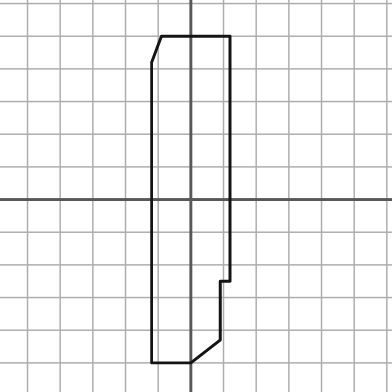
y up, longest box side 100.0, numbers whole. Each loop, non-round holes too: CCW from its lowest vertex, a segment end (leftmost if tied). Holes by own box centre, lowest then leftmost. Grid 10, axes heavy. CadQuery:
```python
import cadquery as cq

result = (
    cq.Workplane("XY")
    .moveTo(-12.0, -50.0)
    .lineTo(0.0, -50.0)
    .lineTo(9.0, -43.0)
    .lineTo(9.0, -25.0)
    .lineTo(12.0, -25.0)
    .lineTo(12.0, 50.0)
    .lineTo(-9.0, 50.0)
    .lineTo(-12.0, 42.0)
    .close()
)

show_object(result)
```